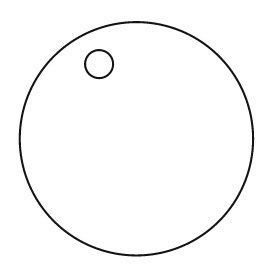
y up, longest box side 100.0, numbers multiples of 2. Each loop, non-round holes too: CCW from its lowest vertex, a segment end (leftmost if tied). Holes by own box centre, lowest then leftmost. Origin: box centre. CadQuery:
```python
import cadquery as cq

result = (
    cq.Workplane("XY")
    .moveTo(0.0, 0.0)
    .circle(50.0)
    .moveTo(-16.0, 32.0)
    .circle(6.0)
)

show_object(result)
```